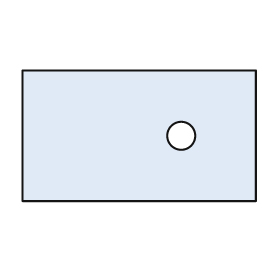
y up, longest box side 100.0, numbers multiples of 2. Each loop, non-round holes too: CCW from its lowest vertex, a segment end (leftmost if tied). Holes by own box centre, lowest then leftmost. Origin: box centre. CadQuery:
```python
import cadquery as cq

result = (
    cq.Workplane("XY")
    .moveTo(-50.0, -28.0)
    .lineTo(50.0, -28.0)
    .lineTo(50.0, 28.0)
    .lineTo(-50.0, 28.0)
    .close()
    .moveTo(18.0, 0.0)
    .circle(6.0)
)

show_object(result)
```